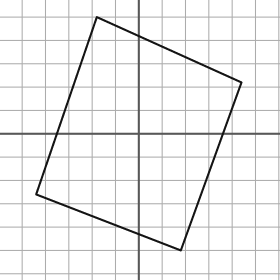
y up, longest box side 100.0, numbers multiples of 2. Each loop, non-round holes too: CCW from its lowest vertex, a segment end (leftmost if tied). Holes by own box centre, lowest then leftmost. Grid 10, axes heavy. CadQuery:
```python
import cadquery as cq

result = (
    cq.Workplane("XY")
    .moveTo(18.0, -50.0)
    .lineTo(44.0, 22.0)
    .lineTo(-18.0, 50.0)
    .lineTo(-44.0, -26.0)
    .close()
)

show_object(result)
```